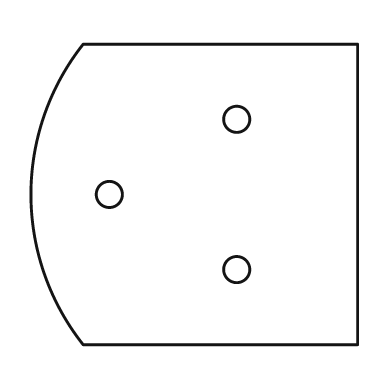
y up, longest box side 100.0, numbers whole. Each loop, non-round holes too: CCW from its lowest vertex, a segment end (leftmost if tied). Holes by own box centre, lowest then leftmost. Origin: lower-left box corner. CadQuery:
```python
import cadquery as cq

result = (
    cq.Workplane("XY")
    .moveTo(16.0, 0.0)
    .lineTo(100.0, 0.0)
    .lineTo(100.0, 92.0)
    .lineTo(16.0, 92.0)
    .threePointArc((0.0, 46.0), (16.0, 0.0))
    .close()
    .moveTo(63.0, 23.0)
    .circle(4.0)
    .moveTo(24.0, 46.0)
    .circle(4.0)
    .moveTo(63.0, 69.0)
    .circle(4.0)
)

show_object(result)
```